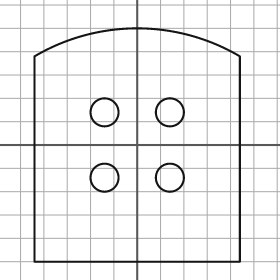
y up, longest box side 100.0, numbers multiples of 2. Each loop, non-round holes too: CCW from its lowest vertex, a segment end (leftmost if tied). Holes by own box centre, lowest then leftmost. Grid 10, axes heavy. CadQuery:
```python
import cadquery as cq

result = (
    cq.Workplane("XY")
    .moveTo(-44.0, -50.0)
    .lineTo(44.0, -50.0)
    .lineTo(44.0, 38.0)
    .threePointArc((0.0, 50.0), (-44.0, 38.0))
    .close()
    .moveTo(-14.0, -14.0)
    .circle(6.0)
    .moveTo(14.0, -14.0)
    .circle(6.0)
    .moveTo(-14.0, 14.0)
    .circle(6.0)
    .moveTo(14.0, 14.0)
    .circle(6.0)
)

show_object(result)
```